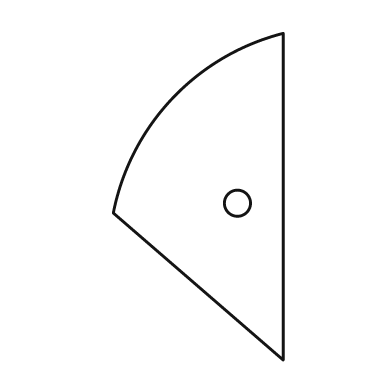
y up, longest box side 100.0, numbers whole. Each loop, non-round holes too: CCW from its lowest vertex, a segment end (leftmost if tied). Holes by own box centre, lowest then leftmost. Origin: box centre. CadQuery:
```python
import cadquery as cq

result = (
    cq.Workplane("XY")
    .moveTo(26.0, -50.0)
    .lineTo(26.0, 50.0)
    .threePointArc((-8.0, 30.0), (-26.0, -5.0))
    .close()
    .moveTo(12.0, -2.0)
    .circle(4.0)
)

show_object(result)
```